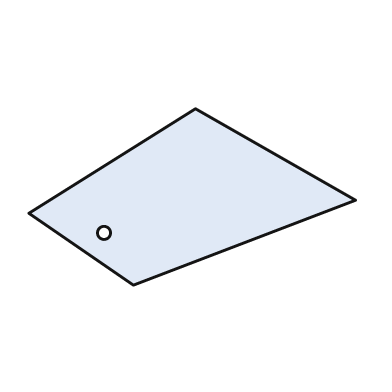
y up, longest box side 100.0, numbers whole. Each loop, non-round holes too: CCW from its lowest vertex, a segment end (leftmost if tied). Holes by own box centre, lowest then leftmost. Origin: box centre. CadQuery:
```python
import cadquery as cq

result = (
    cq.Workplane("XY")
    .moveTo(-18.0, -27.0)
    .lineTo(50.0, -1.0)
    .lineTo(1.0, 27.0)
    .lineTo(-50.0, -5.0)
    .close()
    .moveTo(-27.0, -11.0)
    .circle(2.0)
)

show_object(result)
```